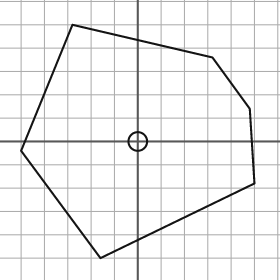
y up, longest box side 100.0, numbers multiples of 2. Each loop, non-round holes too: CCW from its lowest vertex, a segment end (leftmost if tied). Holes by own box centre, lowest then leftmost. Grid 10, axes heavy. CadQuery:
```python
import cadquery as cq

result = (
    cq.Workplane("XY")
    .moveTo(-16.0, -50.0)
    .lineTo(50.0, -18.0)
    .lineTo(48.0, 14.0)
    .lineTo(32.0, 36.0)
    .lineTo(-28.0, 50.0)
    .lineTo(-50.0, -4.0)
    .close()
    .moveTo(0.0, 0.0)
    .circle(4.0)
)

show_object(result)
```